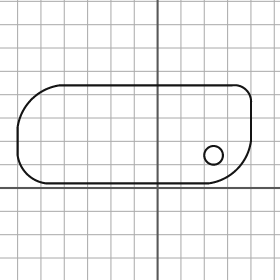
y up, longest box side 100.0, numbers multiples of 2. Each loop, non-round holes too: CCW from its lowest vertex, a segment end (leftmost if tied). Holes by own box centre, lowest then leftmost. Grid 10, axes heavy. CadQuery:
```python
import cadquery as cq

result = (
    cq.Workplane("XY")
    .moveTo(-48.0, 2.0)
    .lineTo(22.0, 2.0)
    .threePointArc((34.0, 8.0), (40.0, 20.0))
    .lineTo(40.0, 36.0)
    .threePointArc((38.0, 42.0), (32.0, 44.0))
    .lineTo(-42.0, 44.0)
    .threePointArc((-54.0, 38.0), (-60.0, 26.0))
    .lineTo(-60.0, 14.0)
    .threePointArc((-56.0, 6.0), (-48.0, 2.0))
    .close()
    .moveTo(24.0, 14.0)
    .circle(4.0)
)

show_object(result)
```